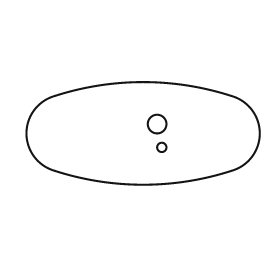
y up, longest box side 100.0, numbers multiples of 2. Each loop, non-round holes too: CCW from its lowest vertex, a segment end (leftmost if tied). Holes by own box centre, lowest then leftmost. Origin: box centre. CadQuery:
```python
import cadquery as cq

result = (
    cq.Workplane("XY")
    .moveTo(-38.0, -16.0)
    .threePointArc((0.0, -22.0), (38.0, -16.0))
    .threePointArc((50.0, 0.0), (38.0, 16.0))
    .threePointArc((0.0, 22.0), (-38.0, 16.0))
    .threePointArc((-50.0, 0.0), (-38.0, -16.0))
    .close()
    .moveTo(8.0, -6.0)
    .circle(2.0)
    .moveTo(6.0, 4.0)
    .circle(4.0)
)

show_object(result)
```